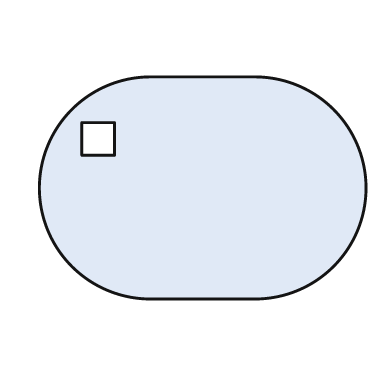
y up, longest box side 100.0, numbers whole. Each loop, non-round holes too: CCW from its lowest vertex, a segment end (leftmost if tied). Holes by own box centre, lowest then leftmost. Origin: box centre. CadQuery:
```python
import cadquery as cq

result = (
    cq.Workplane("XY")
    .moveTo(-16.0, -34.0)
    .lineTo(16.0, -34.0)
    .threePointArc((50.0, 0.0), (16.0, 34.0))
    .lineTo(-16.0, 34.0)
    .threePointArc((-50.0, 0.0), (-16.0, -34.0))
    .close()
    .moveTo(-37.0, 10.0)
    .lineTo(-27.0, 10.0)
    .lineTo(-27.0, 20.0)
    .lineTo(-37.0, 20.0)
    .close()
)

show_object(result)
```